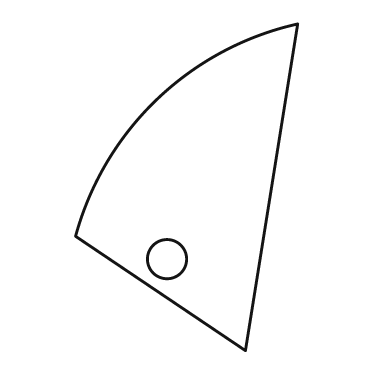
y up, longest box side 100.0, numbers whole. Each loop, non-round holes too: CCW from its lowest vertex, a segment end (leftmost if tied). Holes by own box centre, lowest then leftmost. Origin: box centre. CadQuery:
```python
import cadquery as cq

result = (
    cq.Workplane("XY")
    .moveTo(18.0, -50.0)
    .lineTo(34.0, 50.0)
    .threePointArc((-9.0, 27.0), (-34.0, -15.0))
    .close()
    .moveTo(-6.0, -22.0)
    .circle(6.0)
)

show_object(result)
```